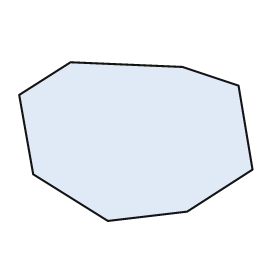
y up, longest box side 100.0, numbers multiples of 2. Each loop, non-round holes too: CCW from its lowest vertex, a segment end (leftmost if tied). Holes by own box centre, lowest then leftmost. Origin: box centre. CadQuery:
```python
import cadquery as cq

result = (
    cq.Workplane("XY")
    .moveTo(-12.0, -34.0)
    .lineTo(22.0, -30.0)
    .lineTo(50.0, -12.0)
    .lineTo(44.0, 24.0)
    .lineTo(20.0, 32.0)
    .lineTo(-28.0, 34.0)
    .lineTo(-50.0, 20.0)
    .lineTo(-44.0, -14.0)
    .close()
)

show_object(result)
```